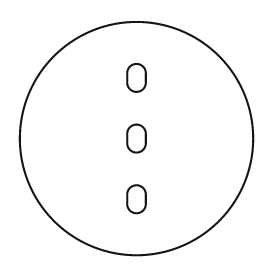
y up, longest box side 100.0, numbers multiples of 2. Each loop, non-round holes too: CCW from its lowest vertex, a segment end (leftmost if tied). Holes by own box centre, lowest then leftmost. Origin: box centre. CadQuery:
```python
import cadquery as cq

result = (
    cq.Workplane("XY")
    .moveTo(0.0, 0.0)
    .circle(50.0)
    .moveTo(-4.0, -28.0)
    .threePointArc((0.0, -32.0), (4.0, -28.0))
    .lineTo(4.0, -24.0)
    .threePointArc((0.0, -20.0), (-4.0, -24.0))
    .close()
    .moveTo(-4.0, -2.0)
    .threePointArc((0.0, -6.0), (4.0, -2.0))
    .lineTo(4.0, 2.0)
    .threePointArc((0.0, 6.0), (-4.0, 2.0))
    .close()
    .moveTo(-4.0, 24.0)
    .threePointArc((0.0, 20.0), (4.0, 24.0))
    .lineTo(4.0, 28.0)
    .threePointArc((0.0, 32.0), (-4.0, 28.0))
    .close()
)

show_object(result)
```